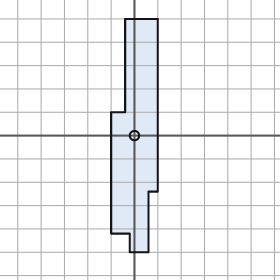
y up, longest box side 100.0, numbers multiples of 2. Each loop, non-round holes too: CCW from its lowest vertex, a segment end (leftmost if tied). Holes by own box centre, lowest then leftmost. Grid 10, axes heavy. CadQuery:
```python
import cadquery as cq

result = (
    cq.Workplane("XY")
    .moveTo(-2.0, -50.0)
    .lineTo(6.0, -50.0)
    .lineTo(6.0, -24.0)
    .lineTo(10.0, -24.0)
    .lineTo(10.0, 50.0)
    .lineTo(-4.0, 50.0)
    .lineTo(-4.0, 10.0)
    .lineTo(-10.0, 10.0)
    .lineTo(-10.0, -42.0)
    .lineTo(-2.0, -42.0)
    .close()
    .moveTo(0.0, 0.0)
    .circle(2.0)
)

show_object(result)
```